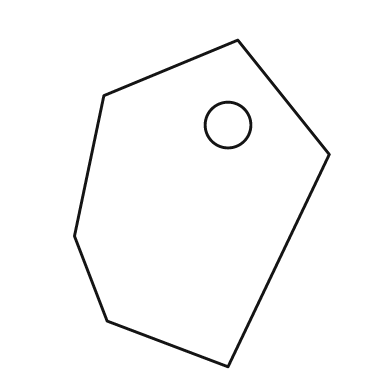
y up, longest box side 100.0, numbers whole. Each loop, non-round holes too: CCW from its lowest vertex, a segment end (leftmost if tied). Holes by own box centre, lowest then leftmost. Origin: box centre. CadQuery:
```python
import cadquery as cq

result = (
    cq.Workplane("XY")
    .moveTo(8.0, -50.0)
    .lineTo(39.0, 15.0)
    .lineTo(11.0, 50.0)
    .lineTo(-30.0, 33.0)
    .lineTo(-39.0, -10.0)
    .lineTo(-29.0, -36.0)
    .close()
    .moveTo(8.0, 24.0)
    .circle(7.0)
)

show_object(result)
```